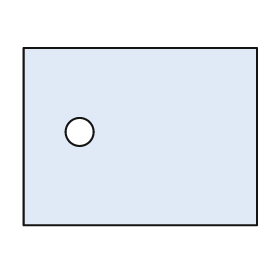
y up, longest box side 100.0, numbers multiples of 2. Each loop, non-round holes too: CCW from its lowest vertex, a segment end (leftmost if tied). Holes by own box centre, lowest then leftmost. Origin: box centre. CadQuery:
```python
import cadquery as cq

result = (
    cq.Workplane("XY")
    .moveTo(-50.0, -38.0)
    .lineTo(50.0, -38.0)
    .lineTo(50.0, 38.0)
    .lineTo(-50.0, 38.0)
    .close()
    .moveTo(-26.0, 2.0)
    .circle(6.0)
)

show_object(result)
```